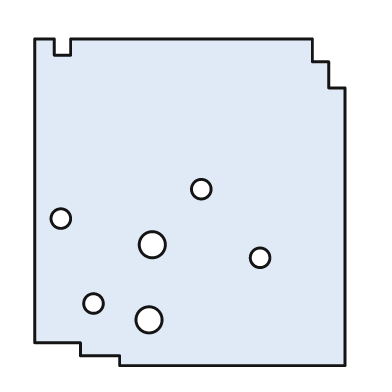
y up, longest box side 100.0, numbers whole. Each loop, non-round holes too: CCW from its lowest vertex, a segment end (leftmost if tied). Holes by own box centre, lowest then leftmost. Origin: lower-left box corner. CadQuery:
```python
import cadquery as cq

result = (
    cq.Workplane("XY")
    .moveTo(26.0, 0.0)
    .lineTo(95.0, 0.0)
    .lineTo(95.0, 85.0)
    .lineTo(90.0, 85.0)
    .lineTo(90.0, 93.0)
    .lineTo(85.0, 93.0)
    .lineTo(85.0, 100.0)
    .lineTo(11.0, 100.0)
    .lineTo(11.0, 95.0)
    .lineTo(6.0, 95.0)
    .lineTo(6.0, 100.0)
    .lineTo(0.0, 100.0)
    .lineTo(0.0, 7.0)
    .lineTo(14.0, 7.0)
    .lineTo(14.0, 3.0)
    .lineTo(26.0, 3.0)
    .close()
    .moveTo(35.0, 14.0)
    .circle(4.0)
    .moveTo(18.0, 19.0)
    .circle(3.0)
    .moveTo(69.0, 33.0)
    .circle(3.0)
    .moveTo(36.0, 37.0)
    .circle(4.0)
    .moveTo(8.0, 45.0)
    .circle(3.0)
    .moveTo(51.0, 54.0)
    .circle(3.0)
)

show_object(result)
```